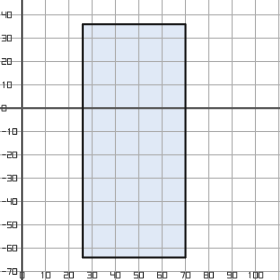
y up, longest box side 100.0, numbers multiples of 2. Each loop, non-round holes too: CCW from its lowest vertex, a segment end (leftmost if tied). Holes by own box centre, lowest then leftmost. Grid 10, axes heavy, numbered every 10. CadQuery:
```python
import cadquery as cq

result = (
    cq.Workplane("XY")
    .moveTo(26.0, -64.0)
    .lineTo(70.0, -64.0)
    .lineTo(70.0, 36.0)
    .lineTo(26.0, 36.0)
    .close()
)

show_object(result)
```